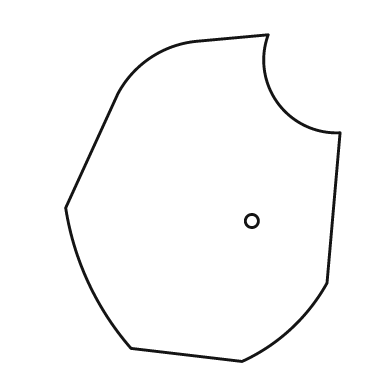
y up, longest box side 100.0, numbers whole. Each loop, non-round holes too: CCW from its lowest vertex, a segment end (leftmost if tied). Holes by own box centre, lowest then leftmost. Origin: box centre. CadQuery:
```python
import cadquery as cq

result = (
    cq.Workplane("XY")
    .moveTo(12.0, -50.0)
    .threePointArc((27.0, -40.0), (38.0, -26.0))
    .lineTo(42.0, 20.0)
    .threePointArc((23.0, 29.0), (20.0, 50.0))
    .lineTo(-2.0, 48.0)
    .threePointArc((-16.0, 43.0), (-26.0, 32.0))
    .lineTo(-42.0, -3.0)
    .threePointArc((-35.0, -26.0), (-22.0, -46.0))
    .close()
    .moveTo(15.0, -7.0)
    .circle(2.0)
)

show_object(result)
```